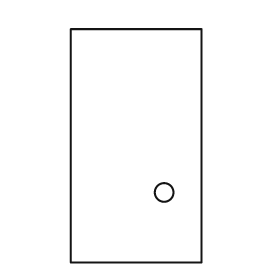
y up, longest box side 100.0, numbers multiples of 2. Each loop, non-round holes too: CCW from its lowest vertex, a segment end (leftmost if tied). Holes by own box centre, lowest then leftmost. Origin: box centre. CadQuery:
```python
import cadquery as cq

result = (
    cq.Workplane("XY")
    .moveTo(-28.0, -50.0)
    .lineTo(28.0, -50.0)
    .lineTo(28.0, 50.0)
    .lineTo(-28.0, 50.0)
    .close()
    .moveTo(12.0, -20.0)
    .circle(4.0)
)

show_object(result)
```